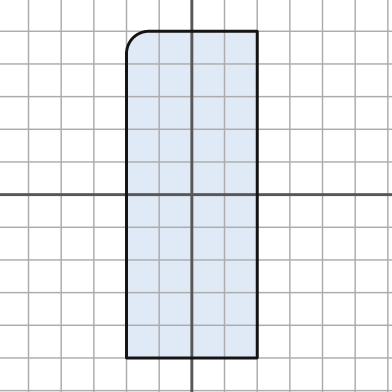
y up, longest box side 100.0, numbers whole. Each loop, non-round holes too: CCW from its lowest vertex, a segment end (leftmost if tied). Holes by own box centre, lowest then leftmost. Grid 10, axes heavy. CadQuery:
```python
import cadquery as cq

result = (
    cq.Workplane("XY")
    .moveTo(-20.0, -50.0)
    .lineTo(20.0, -50.0)
    .lineTo(20.0, 50.0)
    .lineTo(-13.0, 50.0)
    .threePointArc((-18.0, 48.0), (-20.0, 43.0))
    .close()
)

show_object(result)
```